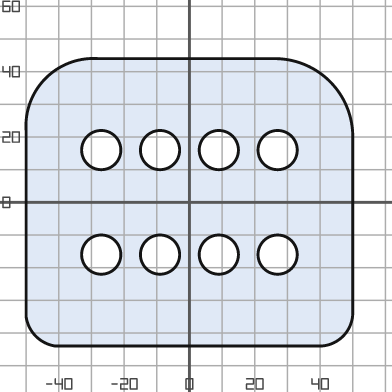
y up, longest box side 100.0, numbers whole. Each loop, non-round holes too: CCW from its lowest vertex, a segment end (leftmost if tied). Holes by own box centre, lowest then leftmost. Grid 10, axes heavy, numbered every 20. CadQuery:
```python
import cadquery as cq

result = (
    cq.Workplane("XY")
    .moveTo(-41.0, -44.0)
    .lineTo(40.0, -44.0)
    .threePointArc((47.0, -41.0), (50.0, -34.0))
    .lineTo(50.0, 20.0)
    .threePointArc((43.0, 37.0), (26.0, 44.0))
    .lineTo(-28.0, 44.0)
    .threePointArc((-44.0, 38.0), (-50.0, 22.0))
    .lineTo(-50.0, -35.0)
    .threePointArc((-47.0, -41.0), (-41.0, -44.0))
    .close()
    .moveTo(-27.0, -16.0)
    .circle(6.0)
    .moveTo(-9.0, -16.0)
    .circle(6.0)
    .moveTo(9.0, -16.0)
    .circle(6.0)
    .moveTo(27.0, -16.0)
    .circle(6.0)
    .moveTo(-27.0, 16.0)
    .circle(6.0)
    .moveTo(-9.0, 16.0)
    .circle(6.0)
    .moveTo(9.0, 16.0)
    .circle(6.0)
    .moveTo(27.0, 16.0)
    .circle(6.0)
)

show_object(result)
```